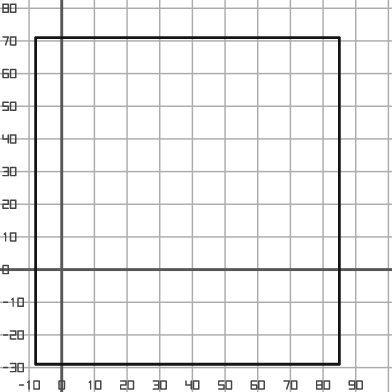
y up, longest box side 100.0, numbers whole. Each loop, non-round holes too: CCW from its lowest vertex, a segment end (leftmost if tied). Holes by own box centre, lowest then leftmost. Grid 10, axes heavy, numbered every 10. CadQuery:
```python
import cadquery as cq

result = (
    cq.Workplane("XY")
    .moveTo(-8.0, -29.0)
    .lineTo(85.0, -29.0)
    .lineTo(85.0, 71.0)
    .lineTo(-8.0, 71.0)
    .close()
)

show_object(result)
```